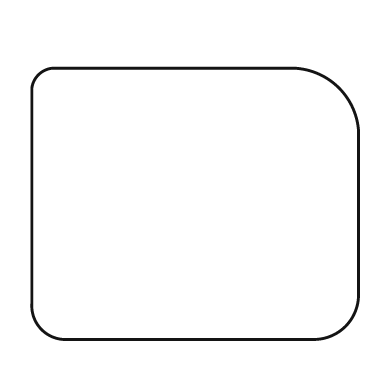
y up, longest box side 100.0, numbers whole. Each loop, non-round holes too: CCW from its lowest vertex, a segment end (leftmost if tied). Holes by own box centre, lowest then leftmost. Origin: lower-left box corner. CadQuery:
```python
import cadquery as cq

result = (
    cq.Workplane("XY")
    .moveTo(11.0, 0.0)
    .lineTo(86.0, 0.0)
    .threePointArc((96.0, 4.0), (100.0, 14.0))
    .lineTo(100.0, 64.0)
    .threePointArc((94.0, 77.0), (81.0, 83.0))
    .lineTo(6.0, 83.0)
    .threePointArc((2.0, 81.0), (0.0, 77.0))
    .lineTo(0.0, 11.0)
    .threePointArc((3.0, 3.0), (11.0, 0.0))
    .close()
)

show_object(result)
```